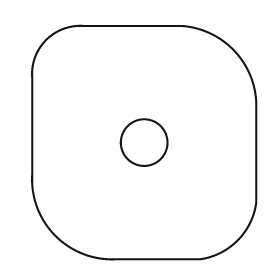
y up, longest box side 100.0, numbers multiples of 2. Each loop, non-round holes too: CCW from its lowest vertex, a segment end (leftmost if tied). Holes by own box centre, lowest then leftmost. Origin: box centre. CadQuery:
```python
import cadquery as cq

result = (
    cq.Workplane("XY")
    .moveTo(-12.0, -50.0)
    .lineTo(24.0, -50.0)
    .threePointArc((40.0, -42.0), (48.0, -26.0))
    .lineTo(48.0, 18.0)
    .threePointArc((38.0, 40.0), (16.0, 50.0))
    .lineTo(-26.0, 50.0)
    .threePointArc((-42.0, 44.0), (-48.0, 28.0))
    .lineTo(-48.0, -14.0)
    .threePointArc((-38.0, -40.0), (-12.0, -50.0))
    .close()
    .moveTo(0.0, 0.0)
    .circle(10.0)
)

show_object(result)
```